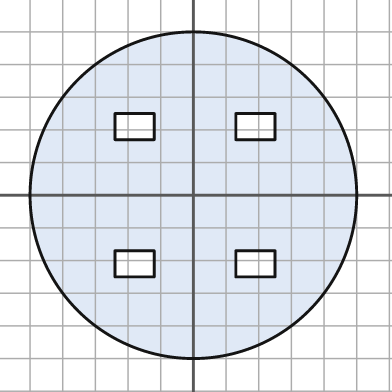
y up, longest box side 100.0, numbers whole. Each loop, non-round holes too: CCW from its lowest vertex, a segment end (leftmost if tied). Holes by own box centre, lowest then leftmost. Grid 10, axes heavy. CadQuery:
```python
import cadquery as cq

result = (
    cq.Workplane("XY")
    .moveTo(0.0, 0.0)
    .circle(50.0)
    .moveTo(-24.0, -25.0)
    .lineTo(-12.0, -25.0)
    .lineTo(-12.0, -17.0)
    .lineTo(-24.0, -17.0)
    .close()
    .moveTo(13.0, -25.0)
    .lineTo(25.0, -25.0)
    .lineTo(25.0, -17.0)
    .lineTo(13.0, -17.0)
    .close()
    .moveTo(-24.0, 17.0)
    .lineTo(-12.0, 17.0)
    .lineTo(-12.0, 25.0)
    .lineTo(-24.0, 25.0)
    .close()
    .moveTo(13.0, 17.0)
    .lineTo(25.0, 17.0)
    .lineTo(25.0, 25.0)
    .lineTo(13.0, 25.0)
    .close()
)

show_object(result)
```